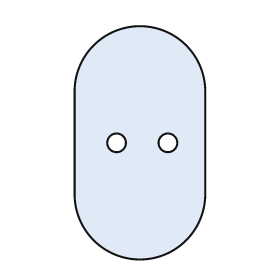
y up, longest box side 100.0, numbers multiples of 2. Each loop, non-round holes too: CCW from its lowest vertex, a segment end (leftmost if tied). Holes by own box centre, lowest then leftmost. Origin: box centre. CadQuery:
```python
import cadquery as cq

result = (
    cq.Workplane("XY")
    .moveTo(-28.0, -22.0)
    .threePointArc((0.0, -50.0), (28.0, -22.0))
    .lineTo(28.0, 22.0)
    .threePointArc((0.0, 50.0), (-28.0, 22.0))
    .close()
    .moveTo(-10.0, 0.0)
    .circle(4.0)
    .moveTo(12.0, 0.0)
    .circle(4.0)
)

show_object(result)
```